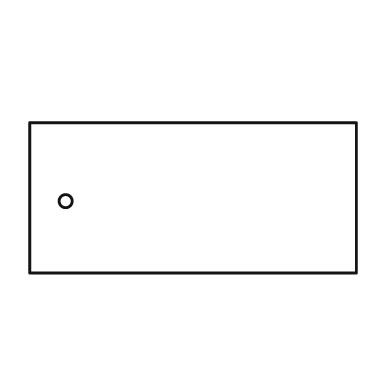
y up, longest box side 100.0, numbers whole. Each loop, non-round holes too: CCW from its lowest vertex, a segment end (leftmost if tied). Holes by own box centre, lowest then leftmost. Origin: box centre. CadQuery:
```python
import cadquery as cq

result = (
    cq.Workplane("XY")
    .moveTo(-50.0, -23.0)
    .lineTo(50.0, -23.0)
    .lineTo(50.0, 23.0)
    .lineTo(-50.0, 23.0)
    .close()
    .moveTo(-39.0, -1.0)
    .circle(2.0)
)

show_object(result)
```